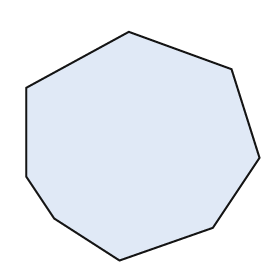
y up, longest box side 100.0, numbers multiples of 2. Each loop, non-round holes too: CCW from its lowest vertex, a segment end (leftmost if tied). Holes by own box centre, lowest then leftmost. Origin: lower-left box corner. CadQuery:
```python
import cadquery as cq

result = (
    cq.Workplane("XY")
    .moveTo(40.0, 0.0)
    .lineTo(80.0, 14.0)
    .lineTo(100.0, 44.0)
    .lineTo(88.0, 82.0)
    .lineTo(44.0, 98.0)
    .lineTo(0.0, 74.0)
    .lineTo(0.0, 36.0)
    .lineTo(12.0, 18.0)
    .close()
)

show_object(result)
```